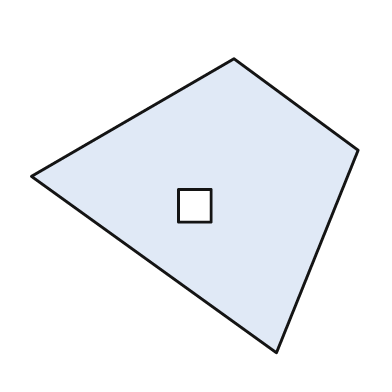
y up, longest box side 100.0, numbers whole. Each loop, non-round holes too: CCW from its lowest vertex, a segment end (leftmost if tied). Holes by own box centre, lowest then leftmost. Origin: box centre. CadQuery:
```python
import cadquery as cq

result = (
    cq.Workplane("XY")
    .moveTo(25.0, -45.0)
    .lineTo(50.0, 17.0)
    .lineTo(12.0, 45.0)
    .lineTo(-50.0, 9.0)
    .close()
    .moveTo(-5.0, -5.0)
    .lineTo(5.0, -5.0)
    .lineTo(5.0, 5.0)
    .lineTo(-5.0, 5.0)
    .close()
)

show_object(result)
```